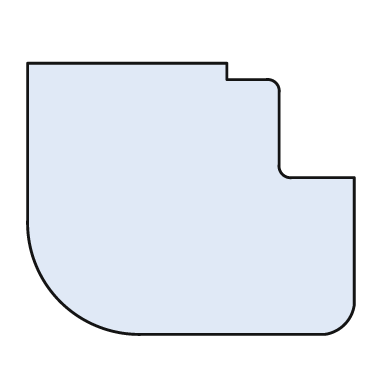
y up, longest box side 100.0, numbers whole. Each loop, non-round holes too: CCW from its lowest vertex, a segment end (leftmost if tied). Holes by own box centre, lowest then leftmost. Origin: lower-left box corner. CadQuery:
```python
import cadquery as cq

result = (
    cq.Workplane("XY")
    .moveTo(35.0, 0.0)
    .lineTo(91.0, 0.0)
    .threePointArc((97.0, 3.0), (100.0, 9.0))
    .lineTo(100.0, 48.0)
    .lineTo(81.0, 48.0)
    .threePointArc((78.0, 49.0), (77.0, 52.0))
    .lineTo(77.0, 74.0)
    .threePointArc((76.0, 77.0), (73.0, 78.0))
    .lineTo(61.0, 78.0)
    .lineTo(61.0, 83.0)
    .lineTo(0.0, 83.0)
    .lineTo(0.0, 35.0)
    .threePointArc((10.0, 10.0), (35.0, 0.0))
    .close()
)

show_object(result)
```